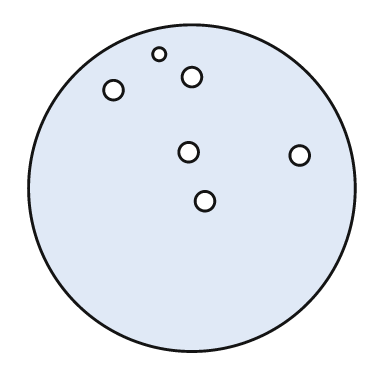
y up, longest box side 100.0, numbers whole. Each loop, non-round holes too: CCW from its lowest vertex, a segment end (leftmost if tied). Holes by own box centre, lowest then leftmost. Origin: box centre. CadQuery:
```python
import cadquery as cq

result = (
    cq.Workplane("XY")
    .moveTo(0.0, 0.0)
    .circle(50.0)
    .moveTo(4.0, -4.0)
    .circle(3.0)
    .moveTo(33.0, 10.0)
    .circle(3.0)
    .moveTo(-1.0, 11.0)
    .circle(3.0)
    .moveTo(-24.0, 30.0)
    .circle(3.0)
    .moveTo(0.0, 34.0)
    .circle(3.0)
    .moveTo(-10.0, 41.0)
    .circle(2.0)
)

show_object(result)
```